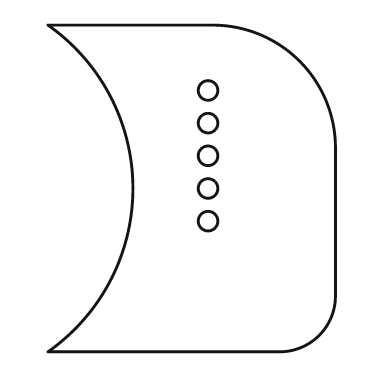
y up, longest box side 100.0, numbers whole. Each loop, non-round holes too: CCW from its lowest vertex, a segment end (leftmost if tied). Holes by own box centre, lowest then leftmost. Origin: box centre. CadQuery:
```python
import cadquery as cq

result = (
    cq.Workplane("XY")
    .moveTo(-44.0, -50.0)
    .lineTo(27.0, -50.0)
    .threePointArc((39.0, -45.0), (44.0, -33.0))
    .lineTo(44.0, 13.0)
    .threePointArc((33.0, 39.0), (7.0, 50.0))
    .lineTo(-44.0, 50.0)
    .threePointArc((-18.0, 0.0), (-44.0, -50.0))
    .close()
    .moveTo(5.0, -10.0)
    .circle(3.0)
    .moveTo(5.0, 0.0)
    .circle(3.0)
    .moveTo(5.0, 10.0)
    .circle(3.0)
    .moveTo(5.0, 20.0)
    .circle(3.0)
    .moveTo(5.0, 30.0)
    .circle(3.0)
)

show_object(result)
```